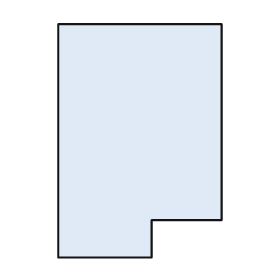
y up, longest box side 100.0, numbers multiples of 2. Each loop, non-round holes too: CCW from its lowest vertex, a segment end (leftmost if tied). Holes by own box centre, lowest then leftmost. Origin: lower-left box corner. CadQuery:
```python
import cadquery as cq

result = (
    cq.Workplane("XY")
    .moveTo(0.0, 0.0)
    .lineTo(40.0, 0.0)
    .lineTo(40.0, 16.0)
    .lineTo(70.0, 16.0)
    .lineTo(70.0, 100.0)
    .lineTo(0.0, 100.0)
    .close()
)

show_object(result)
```